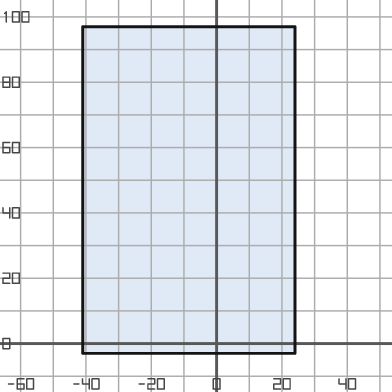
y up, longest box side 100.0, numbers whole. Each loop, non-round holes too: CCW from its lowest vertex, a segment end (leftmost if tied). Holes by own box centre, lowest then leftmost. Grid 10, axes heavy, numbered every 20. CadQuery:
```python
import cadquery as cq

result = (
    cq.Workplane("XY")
    .moveTo(-41.0, -3.0)
    .lineTo(24.0, -3.0)
    .lineTo(24.0, 97.0)
    .lineTo(-41.0, 97.0)
    .close()
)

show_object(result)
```